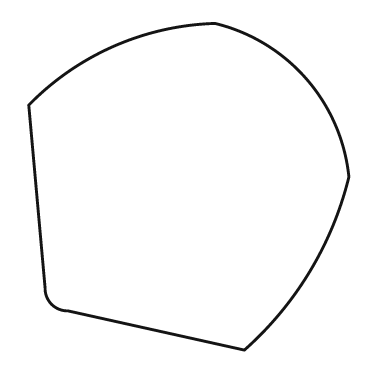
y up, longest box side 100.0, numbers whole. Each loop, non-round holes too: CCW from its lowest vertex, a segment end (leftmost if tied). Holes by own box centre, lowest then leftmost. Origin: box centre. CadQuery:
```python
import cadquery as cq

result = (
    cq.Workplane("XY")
    .moveTo(17.0, -50.0)
    .threePointArc((37.0, -26.0), (49.0, 3.0))
    .threePointArc((36.0, 33.0), (8.0, 50.0))
    .threePointArc((-23.0, 43.0), (-49.0, 25.0))
    .lineTo(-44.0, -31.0)
    .threePointArc((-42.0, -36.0), (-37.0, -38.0))
    .close()
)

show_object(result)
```